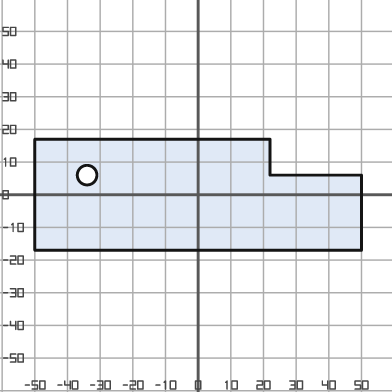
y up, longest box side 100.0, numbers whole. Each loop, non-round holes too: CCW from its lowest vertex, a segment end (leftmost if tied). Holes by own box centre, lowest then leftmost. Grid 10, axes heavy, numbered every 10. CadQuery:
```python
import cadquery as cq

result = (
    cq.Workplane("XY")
    .moveTo(-50.0, -17.0)
    .lineTo(50.0, -17.0)
    .lineTo(50.0, 6.0)
    .lineTo(22.0, 6.0)
    .lineTo(22.0, 17.0)
    .lineTo(-50.0, 17.0)
    .close()
    .moveTo(-34.0, 6.0)
    .circle(3.0)
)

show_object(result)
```